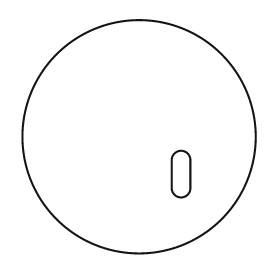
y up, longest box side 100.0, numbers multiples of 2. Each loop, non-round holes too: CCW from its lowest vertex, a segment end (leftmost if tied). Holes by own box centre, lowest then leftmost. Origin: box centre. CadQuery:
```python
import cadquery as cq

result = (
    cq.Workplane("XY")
    .moveTo(0.0, 0.0)
    .circle(50.0)
    .moveTo(14.0, -22.0)
    .threePointArc((18.0, -26.0), (22.0, -22.0))
    .lineTo(22.0, -10.0)
    .threePointArc((18.0, -6.0), (14.0, -10.0))
    .close()
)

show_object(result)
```